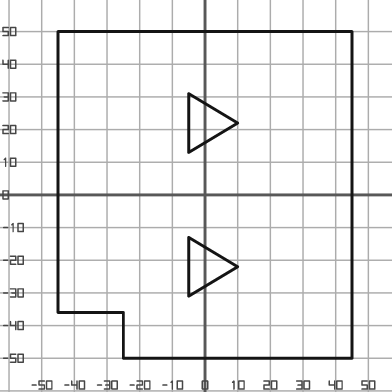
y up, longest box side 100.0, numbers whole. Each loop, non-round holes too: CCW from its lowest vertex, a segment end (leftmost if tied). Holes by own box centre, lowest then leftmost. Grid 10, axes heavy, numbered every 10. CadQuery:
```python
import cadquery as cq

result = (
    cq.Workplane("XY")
    .moveTo(-25.0, -50.0)
    .lineTo(45.0, -50.0)
    .lineTo(45.0, 50.0)
    .lineTo(-45.0, 50.0)
    .lineTo(-45.0, -36.0)
    .lineTo(-25.0, -36.0)
    .close()
    .moveTo(-5.0, -31.0)
    .lineTo(10.0, -22.0)
    .lineTo(-5.0, -13.0)
    .close()
    .moveTo(-5.0, 13.0)
    .lineTo(10.0, 22.0)
    .lineTo(-5.0, 31.0)
    .close()
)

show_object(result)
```